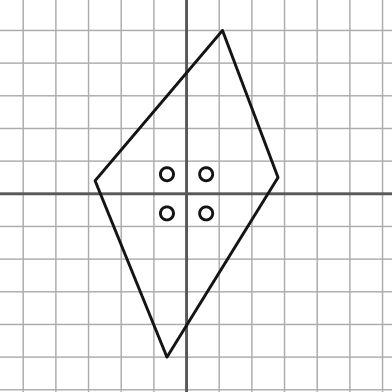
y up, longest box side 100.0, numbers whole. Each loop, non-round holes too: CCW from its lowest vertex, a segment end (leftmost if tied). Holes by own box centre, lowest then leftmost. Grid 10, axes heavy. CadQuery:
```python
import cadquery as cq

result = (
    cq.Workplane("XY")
    .moveTo(-6.0, -50.0)
    .lineTo(28.0, 5.0)
    .lineTo(11.0, 50.0)
    .lineTo(-28.0, 4.0)
    .close()
    .moveTo(-6.0, -6.0)
    .circle(2.0)
    .moveTo(6.0, -6.0)
    .circle(2.0)
    .moveTo(-6.0, 6.0)
    .circle(2.0)
    .moveTo(6.0, 6.0)
    .circle(2.0)
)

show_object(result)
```